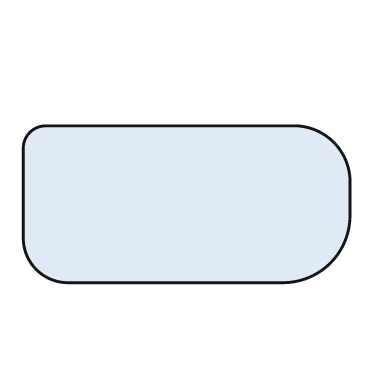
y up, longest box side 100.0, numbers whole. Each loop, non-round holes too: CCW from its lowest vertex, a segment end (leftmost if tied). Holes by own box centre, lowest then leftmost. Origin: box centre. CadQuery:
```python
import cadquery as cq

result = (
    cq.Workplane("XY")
    .moveTo(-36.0, -24.0)
    .lineTo(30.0, -24.0)
    .threePointArc((44.0, -18.0), (50.0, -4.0))
    .lineTo(50.0, 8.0)
    .threePointArc((45.0, 19.0), (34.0, 24.0))
    .lineTo(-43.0, 24.0)
    .threePointArc((-48.0, 22.0), (-50.0, 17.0))
    .lineTo(-50.0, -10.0)
    .threePointArc((-46.0, -20.0), (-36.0, -24.0))
    .close()
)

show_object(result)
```